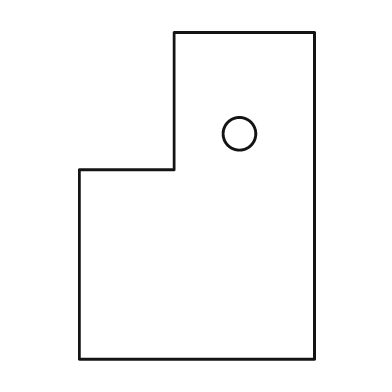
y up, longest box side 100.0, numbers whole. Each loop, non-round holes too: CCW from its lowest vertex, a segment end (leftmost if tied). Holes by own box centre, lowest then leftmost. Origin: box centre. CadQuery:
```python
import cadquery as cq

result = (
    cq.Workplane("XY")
    .moveTo(-36.0, -50.0)
    .lineTo(36.0, -50.0)
    .lineTo(36.0, 50.0)
    .lineTo(-7.0, 50.0)
    .lineTo(-7.0, 8.0)
    .lineTo(-36.0, 8.0)
    .close()
    .moveTo(13.0, 19.0)
    .circle(5.0)
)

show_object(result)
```